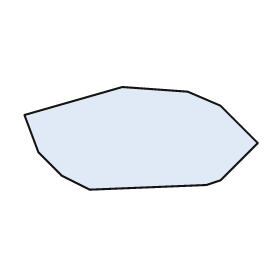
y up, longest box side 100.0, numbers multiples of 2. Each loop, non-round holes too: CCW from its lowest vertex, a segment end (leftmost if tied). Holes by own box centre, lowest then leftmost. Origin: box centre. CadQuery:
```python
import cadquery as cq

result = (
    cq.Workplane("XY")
    .moveTo(-22.0, -22.0)
    .lineTo(28.0, -20.0)
    .lineTo(34.0, -18.0)
    .lineTo(50.0, -2.0)
    .lineTo(34.0, 14.0)
    .lineTo(20.0, 20.0)
    .lineTo(-8.0, 22.0)
    .lineTo(-50.0, 10.0)
    .lineTo(-44.0, -6.0)
    .lineTo(-34.0, -16.0)
    .close()
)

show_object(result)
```